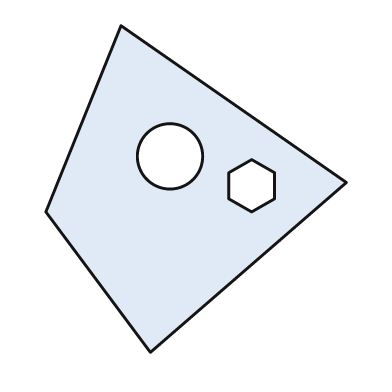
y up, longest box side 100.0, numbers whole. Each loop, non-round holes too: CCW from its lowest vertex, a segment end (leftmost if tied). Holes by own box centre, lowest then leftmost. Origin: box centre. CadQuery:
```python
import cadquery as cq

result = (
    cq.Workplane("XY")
    .moveTo(-14.0, -50.0)
    .lineTo(46.0, 2.0)
    .lineTo(-23.0, 50.0)
    .lineTo(-46.0, -7.0)
    .close()
    .moveTo(17.0, -7.0)
    .lineTo(24.0, -3.0)
    .lineTo(24.0, 5.0)
    .lineTo(17.0, 9.0)
    .lineTo(10.0, 5.0)
    .lineTo(10.0, -3.0)
    .close()
    .moveTo(-8.0, 10.0)
    .circle(10.0)
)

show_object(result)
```